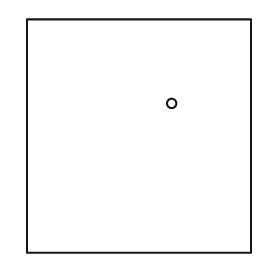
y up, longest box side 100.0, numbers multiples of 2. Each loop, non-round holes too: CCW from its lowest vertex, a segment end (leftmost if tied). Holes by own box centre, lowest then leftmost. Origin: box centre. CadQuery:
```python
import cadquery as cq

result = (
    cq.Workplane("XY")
    .moveTo(-48.0, -50.0)
    .lineTo(48.0, -50.0)
    .lineTo(48.0, 50.0)
    .lineTo(-48.0, 50.0)
    .close()
    .moveTo(14.0, 14.0)
    .circle(2.0)
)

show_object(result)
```